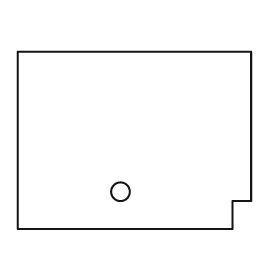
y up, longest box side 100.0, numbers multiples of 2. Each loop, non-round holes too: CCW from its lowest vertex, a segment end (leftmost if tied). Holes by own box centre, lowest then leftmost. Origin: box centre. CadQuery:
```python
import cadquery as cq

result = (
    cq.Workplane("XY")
    .moveTo(-50.0, -38.0)
    .lineTo(42.0, -38.0)
    .lineTo(42.0, -26.0)
    .lineTo(50.0, -26.0)
    .lineTo(50.0, 38.0)
    .lineTo(-50.0, 38.0)
    .close()
    .moveTo(-6.0, -22.0)
    .circle(4.0)
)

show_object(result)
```